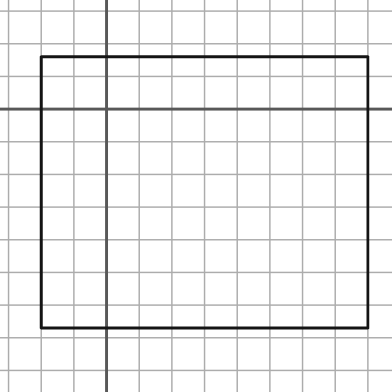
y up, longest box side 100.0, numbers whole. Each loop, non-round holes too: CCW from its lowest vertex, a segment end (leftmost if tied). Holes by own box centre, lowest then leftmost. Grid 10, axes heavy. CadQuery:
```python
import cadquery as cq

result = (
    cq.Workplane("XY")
    .moveTo(-20.0, -67.0)
    .lineTo(80.0, -67.0)
    .lineTo(80.0, 16.0)
    .lineTo(-20.0, 16.0)
    .close()
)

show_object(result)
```